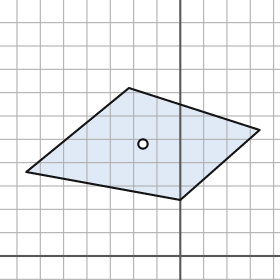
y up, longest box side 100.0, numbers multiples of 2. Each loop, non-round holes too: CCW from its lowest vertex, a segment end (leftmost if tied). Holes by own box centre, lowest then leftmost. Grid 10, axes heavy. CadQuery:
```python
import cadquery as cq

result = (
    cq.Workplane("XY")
    .moveTo(0.0, 24.0)
    .lineTo(34.0, 54.0)
    .lineTo(-22.0, 72.0)
    .lineTo(-66.0, 36.0)
    .close()
    .moveTo(-16.0, 48.0)
    .circle(2.0)
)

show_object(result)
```